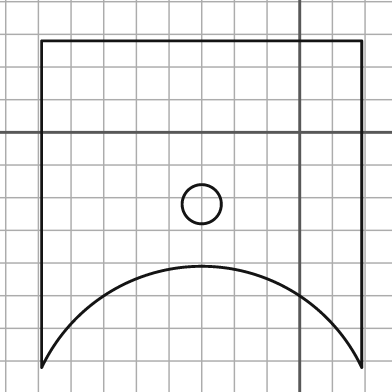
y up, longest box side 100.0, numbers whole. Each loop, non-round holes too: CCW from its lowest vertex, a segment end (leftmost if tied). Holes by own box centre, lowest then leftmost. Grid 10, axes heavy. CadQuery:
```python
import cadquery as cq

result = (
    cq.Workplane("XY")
    .moveTo(-79.0, -72.0)
    .threePointArc((-30.0, -41.0), (19.0, -72.0))
    .lineTo(19.0, 28.0)
    .lineTo(-79.0, 28.0)
    .close()
    .moveTo(-30.0, -22.0)
    .circle(6.0)
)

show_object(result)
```